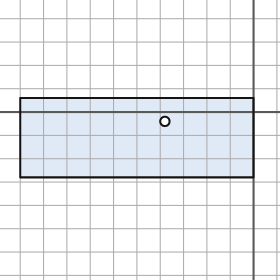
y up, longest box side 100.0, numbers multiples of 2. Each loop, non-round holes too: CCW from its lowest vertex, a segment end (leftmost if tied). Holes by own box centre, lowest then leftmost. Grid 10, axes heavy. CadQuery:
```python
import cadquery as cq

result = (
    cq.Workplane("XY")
    .moveTo(-100.0, -28.0)
    .lineTo(0.0, -28.0)
    .lineTo(0.0, 6.0)
    .lineTo(-100.0, 6.0)
    .close()
    .moveTo(-38.0, -4.0)
    .circle(2.0)
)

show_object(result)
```